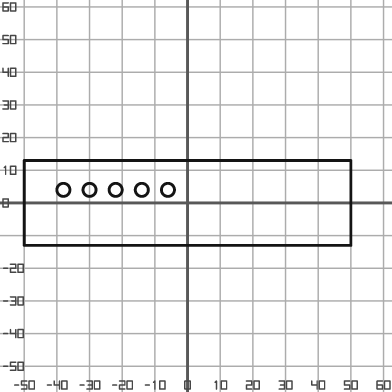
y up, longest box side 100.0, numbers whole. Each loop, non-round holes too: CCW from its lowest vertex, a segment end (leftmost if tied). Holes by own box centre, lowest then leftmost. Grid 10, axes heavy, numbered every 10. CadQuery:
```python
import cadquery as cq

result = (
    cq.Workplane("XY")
    .moveTo(-50.0, -13.0)
    .lineTo(50.0, -13.0)
    .lineTo(50.0, 13.0)
    .lineTo(-50.0, 13.0)
    .close()
    .moveTo(-38.0, 4.0)
    .circle(2.0)
    .moveTo(-30.0, 4.0)
    .circle(2.0)
    .moveTo(-22.0, 4.0)
    .circle(2.0)
    .moveTo(-14.0, 4.0)
    .circle(2.0)
    .moveTo(-6.0, 4.0)
    .circle(2.0)
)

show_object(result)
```